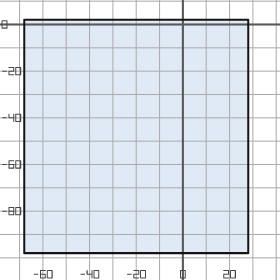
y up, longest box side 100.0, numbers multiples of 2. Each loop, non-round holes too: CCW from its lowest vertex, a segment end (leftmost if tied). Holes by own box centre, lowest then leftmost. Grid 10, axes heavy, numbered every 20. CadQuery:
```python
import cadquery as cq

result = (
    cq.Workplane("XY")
    .moveTo(-68.0, -98.0)
    .lineTo(28.0, -98.0)
    .lineTo(28.0, 2.0)
    .lineTo(-68.0, 2.0)
    .close()
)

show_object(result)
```